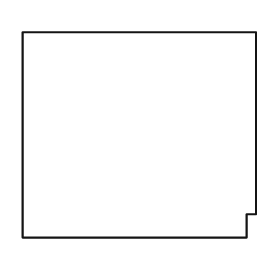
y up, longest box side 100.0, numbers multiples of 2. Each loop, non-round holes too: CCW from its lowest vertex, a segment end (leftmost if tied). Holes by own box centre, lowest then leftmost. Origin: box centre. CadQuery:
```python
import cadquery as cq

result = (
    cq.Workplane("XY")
    .moveTo(-50.0, -44.0)
    .lineTo(46.0, -44.0)
    .lineTo(46.0, -34.0)
    .lineTo(50.0, -34.0)
    .lineTo(50.0, 44.0)
    .lineTo(-50.0, 44.0)
    .close()
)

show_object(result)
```